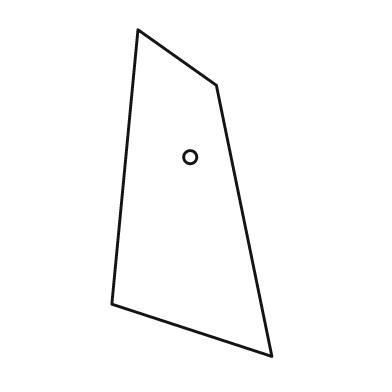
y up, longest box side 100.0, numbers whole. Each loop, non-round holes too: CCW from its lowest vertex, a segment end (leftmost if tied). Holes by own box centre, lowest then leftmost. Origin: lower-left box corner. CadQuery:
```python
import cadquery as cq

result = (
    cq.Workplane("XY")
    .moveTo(49.0, 0.0)
    .lineTo(32.0, 83.0)
    .lineTo(8.0, 100.0)
    .lineTo(0.0, 16.0)
    .close()
    .moveTo(24.0, 61.0)
    .circle(2.0)
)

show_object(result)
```